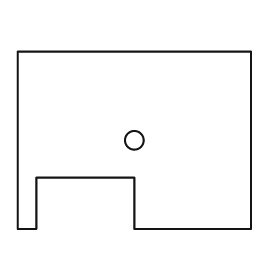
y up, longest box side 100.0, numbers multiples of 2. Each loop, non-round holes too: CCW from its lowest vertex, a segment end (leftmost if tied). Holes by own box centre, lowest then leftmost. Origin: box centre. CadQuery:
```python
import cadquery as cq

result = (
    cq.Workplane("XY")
    .moveTo(-50.0, -38.0)
    .lineTo(-42.0, -38.0)
    .lineTo(-42.0, -16.0)
    .lineTo(0.0, -16.0)
    .lineTo(0.0, -38.0)
    .lineTo(50.0, -38.0)
    .lineTo(50.0, 38.0)
    .lineTo(-50.0, 38.0)
    .close()
    .moveTo(0.0, 0.0)
    .circle(4.0)
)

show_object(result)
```